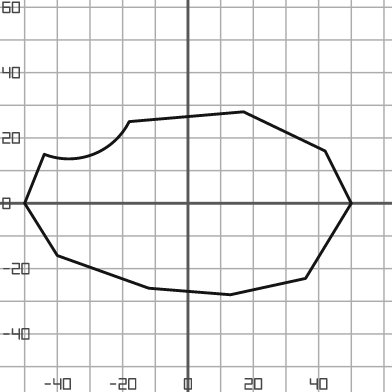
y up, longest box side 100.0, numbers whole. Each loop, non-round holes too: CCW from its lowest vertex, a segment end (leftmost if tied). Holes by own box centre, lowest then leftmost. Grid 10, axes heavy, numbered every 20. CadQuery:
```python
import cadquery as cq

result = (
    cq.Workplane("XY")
    .moveTo(13.0, -28.0)
    .lineTo(36.0, -23.0)
    .lineTo(50.0, 0.0)
    .lineTo(42.0, 16.0)
    .lineTo(17.0, 28.0)
    .lineTo(-18.0, 25.0)
    .threePointArc((-29.0, 15.0), (-44.0, 15.0))
    .lineTo(-50.0, 0.0)
    .lineTo(-40.0, -16.0)
    .lineTo(-12.0, -26.0)
    .close()
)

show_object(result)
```